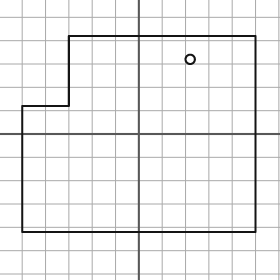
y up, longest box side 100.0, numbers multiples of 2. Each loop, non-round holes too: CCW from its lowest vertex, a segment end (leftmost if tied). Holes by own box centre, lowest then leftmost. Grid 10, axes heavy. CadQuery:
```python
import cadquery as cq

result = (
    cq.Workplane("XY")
    .moveTo(-50.0, -42.0)
    .lineTo(50.0, -42.0)
    .lineTo(50.0, 42.0)
    .lineTo(-30.0, 42.0)
    .lineTo(-30.0, 12.0)
    .lineTo(-50.0, 12.0)
    .close()
    .moveTo(22.0, 32.0)
    .circle(2.0)
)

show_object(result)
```